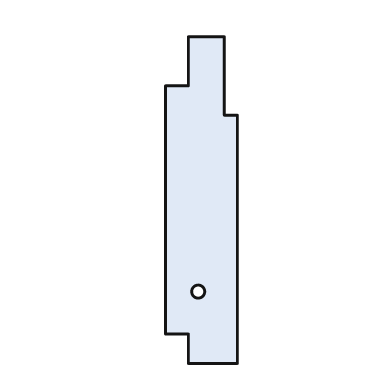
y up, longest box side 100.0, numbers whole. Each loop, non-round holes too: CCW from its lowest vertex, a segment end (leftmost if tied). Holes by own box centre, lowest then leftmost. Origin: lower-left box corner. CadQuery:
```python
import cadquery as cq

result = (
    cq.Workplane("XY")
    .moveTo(7.0, 0.0)
    .lineTo(22.0, 0.0)
    .lineTo(22.0, 76.0)
    .lineTo(18.0, 76.0)
    .lineTo(18.0, 100.0)
    .lineTo(7.0, 100.0)
    .lineTo(7.0, 85.0)
    .lineTo(0.0, 85.0)
    .lineTo(0.0, 9.0)
    .lineTo(7.0, 9.0)
    .close()
    .moveTo(10.0, 22.0)
    .circle(2.0)
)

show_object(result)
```